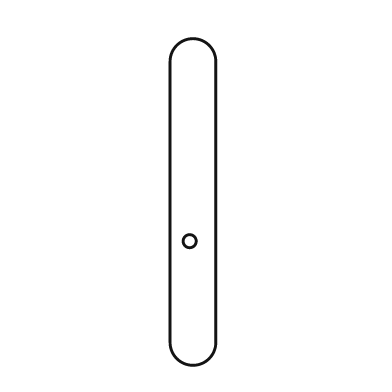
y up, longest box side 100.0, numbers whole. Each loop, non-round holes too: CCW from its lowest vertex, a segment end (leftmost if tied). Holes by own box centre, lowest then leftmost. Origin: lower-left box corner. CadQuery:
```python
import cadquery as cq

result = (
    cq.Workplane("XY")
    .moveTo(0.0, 7.0)
    .threePointArc((7.0, 0.0), (14.0, 7.0))
    .lineTo(14.0, 93.0)
    .threePointArc((7.0, 100.0), (0.0, 93.0))
    .close()
    .moveTo(6.0, 38.0)
    .circle(2.0)
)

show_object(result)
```